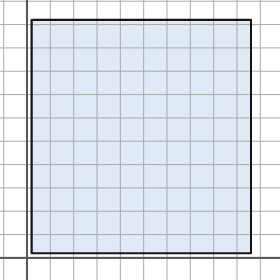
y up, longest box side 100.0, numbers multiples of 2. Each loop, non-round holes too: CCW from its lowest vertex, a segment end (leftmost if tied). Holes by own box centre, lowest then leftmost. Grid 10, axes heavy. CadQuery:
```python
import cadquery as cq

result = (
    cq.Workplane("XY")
    .moveTo(2.0, 2.0)
    .lineTo(96.0, 2.0)
    .lineTo(96.0, 102.0)
    .lineTo(2.0, 102.0)
    .close()
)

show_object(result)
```